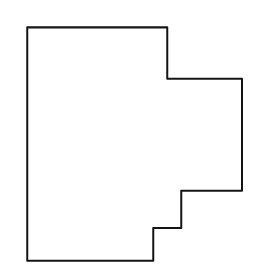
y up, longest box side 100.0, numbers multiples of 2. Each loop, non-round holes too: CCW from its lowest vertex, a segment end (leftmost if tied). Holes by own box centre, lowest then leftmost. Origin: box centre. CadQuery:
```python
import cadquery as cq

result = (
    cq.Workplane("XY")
    .moveTo(-46.0, -50.0)
    .lineTo(8.0, -50.0)
    .lineTo(8.0, -36.0)
    .lineTo(20.0, -36.0)
    .lineTo(20.0, -20.0)
    .lineTo(46.0, -20.0)
    .lineTo(46.0, 28.0)
    .lineTo(14.0, 28.0)
    .lineTo(14.0, 50.0)
    .lineTo(-46.0, 50.0)
    .close()
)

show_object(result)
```